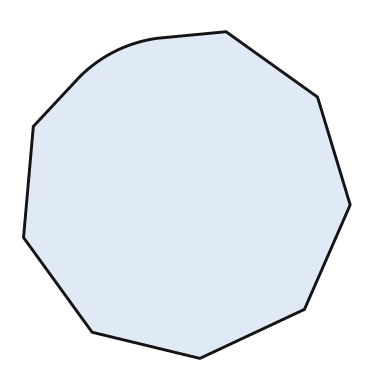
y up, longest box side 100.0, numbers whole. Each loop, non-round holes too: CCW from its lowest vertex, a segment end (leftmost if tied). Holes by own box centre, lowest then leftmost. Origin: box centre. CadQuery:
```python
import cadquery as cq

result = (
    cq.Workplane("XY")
    .moveTo(4.0, -50.0)
    .lineTo(36.0, -35.0)
    .lineTo(50.0, -3.0)
    .lineTo(40.0, 30.0)
    .lineTo(12.0, 50.0)
    .lineTo(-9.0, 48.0)
    .threePointArc((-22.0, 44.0), (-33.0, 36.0))
    .lineTo(-47.0, 21.0)
    .lineTo(-50.0, -13.0)
    .lineTo(-29.0, -42.0)
    .close()
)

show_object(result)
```